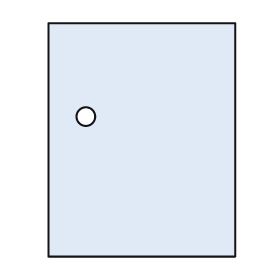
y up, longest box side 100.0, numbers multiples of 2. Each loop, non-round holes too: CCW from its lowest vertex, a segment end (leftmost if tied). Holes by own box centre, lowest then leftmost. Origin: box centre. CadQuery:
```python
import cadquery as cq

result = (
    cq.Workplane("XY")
    .moveTo(-40.0, -50.0)
    .lineTo(40.0, -50.0)
    .lineTo(40.0, 50.0)
    .lineTo(-40.0, 50.0)
    .close()
    .moveTo(-24.0, 10.0)
    .circle(4.0)
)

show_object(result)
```